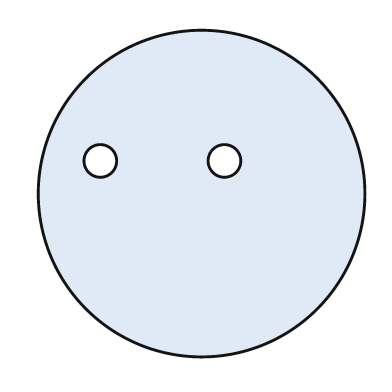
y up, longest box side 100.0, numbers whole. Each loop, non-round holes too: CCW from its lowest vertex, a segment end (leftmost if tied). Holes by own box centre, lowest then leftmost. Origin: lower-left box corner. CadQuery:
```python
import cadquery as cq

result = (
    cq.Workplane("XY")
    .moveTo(50.0, 50.0)
    .circle(50.0)
    .moveTo(19.0, 60.0)
    .circle(5.0)
    .moveTo(57.0, 60.0)
    .circle(5.0)
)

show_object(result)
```